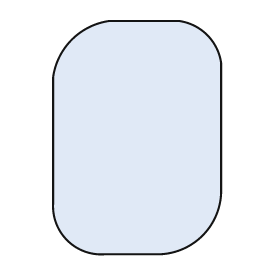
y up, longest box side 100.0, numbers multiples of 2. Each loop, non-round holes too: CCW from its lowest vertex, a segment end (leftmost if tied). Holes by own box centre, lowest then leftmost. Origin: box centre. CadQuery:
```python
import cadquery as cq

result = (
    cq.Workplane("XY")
    .moveTo(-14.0, -50.0)
    .lineTo(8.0, -50.0)
    .threePointArc((28.0, -42.0), (36.0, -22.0))
    .lineTo(36.0, 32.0)
    .threePointArc((30.0, 44.0), (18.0, 50.0))
    .lineTo(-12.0, 50.0)
    .threePointArc((-28.0, 42.0), (-36.0, 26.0))
    .lineTo(-36.0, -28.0)
    .threePointArc((-30.0, -44.0), (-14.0, -50.0))
    .close()
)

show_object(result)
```